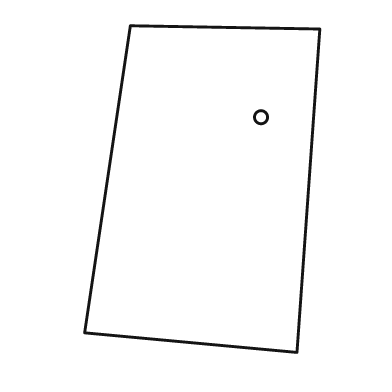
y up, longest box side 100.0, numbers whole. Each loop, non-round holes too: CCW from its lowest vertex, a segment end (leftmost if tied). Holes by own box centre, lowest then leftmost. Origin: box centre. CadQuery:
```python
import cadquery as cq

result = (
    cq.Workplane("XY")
    .moveTo(29.0, -50.0)
    .lineTo(36.0, 49.0)
    .lineTo(-22.0, 50.0)
    .lineTo(-36.0, -44.0)
    .close()
    .moveTo(18.0, 22.0)
    .circle(2.0)
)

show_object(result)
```